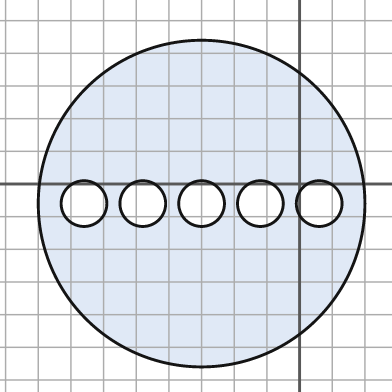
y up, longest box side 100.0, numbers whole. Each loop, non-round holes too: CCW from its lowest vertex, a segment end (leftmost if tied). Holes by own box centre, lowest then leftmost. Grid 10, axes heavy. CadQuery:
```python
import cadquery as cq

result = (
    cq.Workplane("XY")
    .moveTo(-30.0, -6.0)
    .circle(50.0)
    .moveTo(-66.0, -6.0)
    .circle(7.0)
    .moveTo(-48.0, -6.0)
    .circle(7.0)
    .moveTo(-30.0, -6.0)
    .circle(7.0)
    .moveTo(-12.0, -6.0)
    .circle(7.0)
    .moveTo(6.0, -6.0)
    .circle(7.0)
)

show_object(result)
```